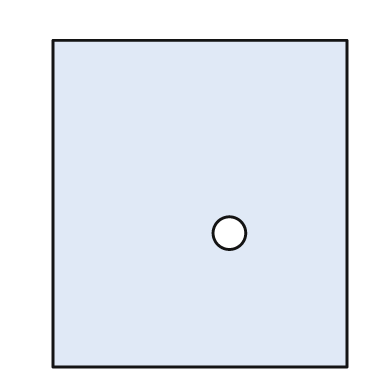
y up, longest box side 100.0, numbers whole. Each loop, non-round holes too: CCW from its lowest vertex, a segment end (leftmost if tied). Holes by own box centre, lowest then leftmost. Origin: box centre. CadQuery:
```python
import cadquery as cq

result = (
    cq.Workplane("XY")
    .moveTo(-45.0, -50.0)
    .lineTo(45.0, -50.0)
    .lineTo(45.0, 50.0)
    .lineTo(-45.0, 50.0)
    .close()
    .moveTo(9.0, -9.0)
    .circle(5.0)
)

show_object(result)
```